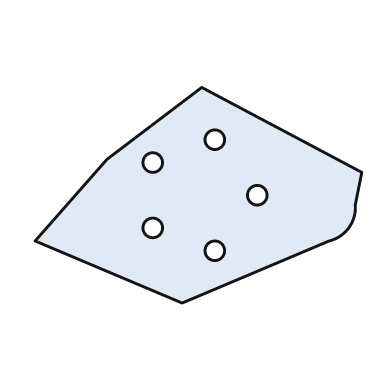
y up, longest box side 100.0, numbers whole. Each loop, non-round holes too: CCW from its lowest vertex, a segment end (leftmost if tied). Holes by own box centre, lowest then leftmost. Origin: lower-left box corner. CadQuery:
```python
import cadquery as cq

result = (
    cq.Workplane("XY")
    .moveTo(45.0, 0.0)
    .lineTo(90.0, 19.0)
    .threePointArc((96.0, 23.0), (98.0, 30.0))
    .lineTo(100.0, 40.0)
    .lineTo(51.0, 66.0)
    .lineTo(22.0, 44.0)
    .lineTo(0.0, 19.0)
    .close()
    .moveTo(55.0, 16.0)
    .circle(3.0)
    .moveTo(36.0, 23.0)
    .circle(3.0)
    .moveTo(68.0, 33.0)
    .circle(3.0)
    .moveTo(36.0, 43.0)
    .circle(3.0)
    .moveTo(55.0, 50.0)
    .circle(3.0)
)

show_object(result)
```